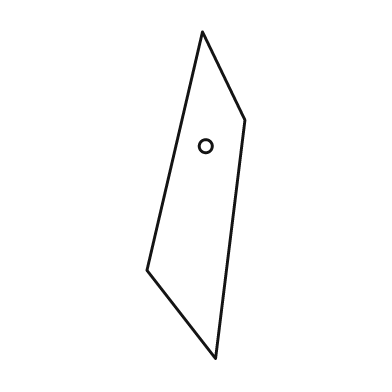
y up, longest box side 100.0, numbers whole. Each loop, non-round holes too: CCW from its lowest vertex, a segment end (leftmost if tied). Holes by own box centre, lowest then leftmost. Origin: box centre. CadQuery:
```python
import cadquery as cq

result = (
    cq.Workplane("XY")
    .moveTo(6.0, -50.0)
    .lineTo(15.0, 23.0)
    .lineTo(2.0, 50.0)
    .lineTo(-15.0, -23.0)
    .close()
    .moveTo(3.0, 15.0)
    .circle(2.0)
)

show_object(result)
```